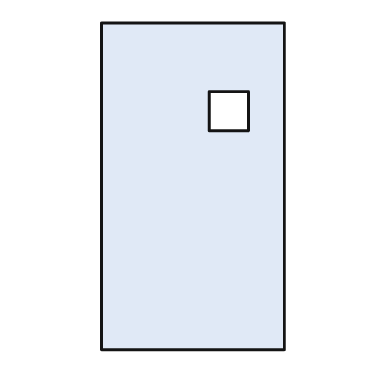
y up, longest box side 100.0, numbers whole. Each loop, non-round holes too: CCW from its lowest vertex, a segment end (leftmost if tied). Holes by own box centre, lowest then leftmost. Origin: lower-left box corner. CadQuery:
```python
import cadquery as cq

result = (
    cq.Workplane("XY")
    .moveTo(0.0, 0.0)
    .lineTo(56.0, 0.0)
    .lineTo(56.0, 100.0)
    .lineTo(0.0, 100.0)
    .close()
    .moveTo(33.0, 67.0)
    .lineTo(45.0, 67.0)
    .lineTo(45.0, 79.0)
    .lineTo(33.0, 79.0)
    .close()
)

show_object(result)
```